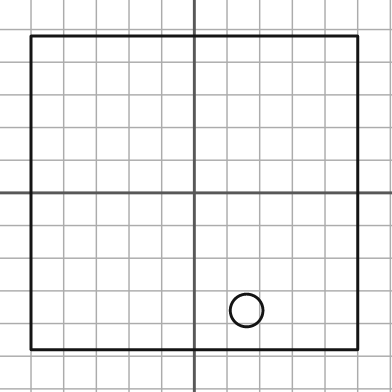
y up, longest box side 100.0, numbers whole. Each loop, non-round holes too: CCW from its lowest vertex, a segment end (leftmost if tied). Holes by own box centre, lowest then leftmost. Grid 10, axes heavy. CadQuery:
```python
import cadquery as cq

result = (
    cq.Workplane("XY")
    .moveTo(-50.0, -48.0)
    .lineTo(50.0, -48.0)
    .lineTo(50.0, 48.0)
    .lineTo(-50.0, 48.0)
    .close()
    .moveTo(16.0, -36.0)
    .circle(5.0)
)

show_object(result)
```